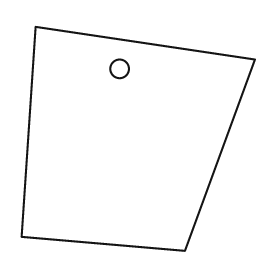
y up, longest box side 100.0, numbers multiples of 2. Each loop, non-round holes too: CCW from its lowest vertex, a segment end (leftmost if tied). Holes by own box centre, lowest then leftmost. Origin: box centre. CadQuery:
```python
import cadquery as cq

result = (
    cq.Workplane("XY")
    .moveTo(20.0, -48.0)
    .lineTo(50.0, 34.0)
    .lineTo(-44.0, 48.0)
    .lineTo(-50.0, -42.0)
    .close()
    .moveTo(-8.0, 30.0)
    .circle(4.0)
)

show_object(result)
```